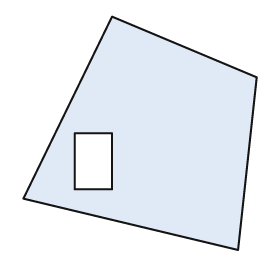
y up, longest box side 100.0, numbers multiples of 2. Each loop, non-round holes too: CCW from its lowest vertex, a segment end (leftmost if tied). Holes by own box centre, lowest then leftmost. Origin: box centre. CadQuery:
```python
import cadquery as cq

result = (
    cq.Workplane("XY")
    .moveTo(42.0, -50.0)
    .lineTo(50.0, 24.0)
    .lineTo(-12.0, 50.0)
    .lineTo(-50.0, -28.0)
    .close()
    .moveTo(-28.0, -24.0)
    .lineTo(-12.0, -24.0)
    .lineTo(-12.0, 0.0)
    .lineTo(-28.0, 0.0)
    .close()
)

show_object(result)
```